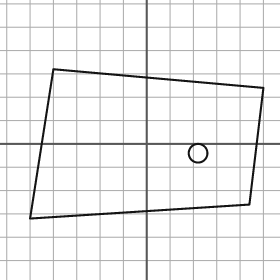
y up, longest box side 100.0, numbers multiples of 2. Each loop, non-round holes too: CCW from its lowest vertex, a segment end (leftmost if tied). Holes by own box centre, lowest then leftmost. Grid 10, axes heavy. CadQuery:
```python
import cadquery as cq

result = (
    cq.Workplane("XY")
    .moveTo(-50.0, -32.0)
    .lineTo(44.0, -26.0)
    .lineTo(50.0, 24.0)
    .lineTo(-40.0, 32.0)
    .close()
    .moveTo(22.0, -4.0)
    .circle(4.0)
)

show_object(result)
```